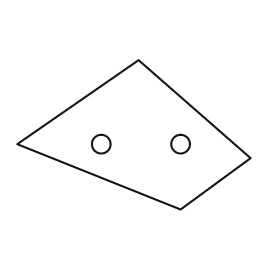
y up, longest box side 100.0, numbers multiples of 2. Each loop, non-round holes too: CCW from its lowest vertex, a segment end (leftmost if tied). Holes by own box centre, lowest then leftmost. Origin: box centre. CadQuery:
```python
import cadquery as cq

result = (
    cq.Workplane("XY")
    .moveTo(20.0, -32.0)
    .lineTo(50.0, -10.0)
    .lineTo(2.0, 32.0)
    .lineTo(-50.0, -4.0)
    .close()
    .moveTo(-14.0, -4.0)
    .circle(4.0)
    .moveTo(20.0, -4.0)
    .circle(4.0)
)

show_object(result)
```